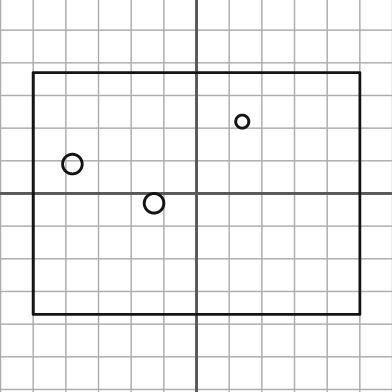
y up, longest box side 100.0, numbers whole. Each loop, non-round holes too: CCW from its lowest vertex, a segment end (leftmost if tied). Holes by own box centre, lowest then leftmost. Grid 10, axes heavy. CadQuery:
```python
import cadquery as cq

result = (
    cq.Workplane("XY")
    .moveTo(-50.0, -37.0)
    .lineTo(50.0, -37.0)
    .lineTo(50.0, 37.0)
    .lineTo(-50.0, 37.0)
    .close()
    .moveTo(-13.0, -3.0)
    .circle(3.0)
    .moveTo(-38.0, 9.0)
    .circle(3.0)
    .moveTo(14.0, 22.0)
    .circle(2.0)
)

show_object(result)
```